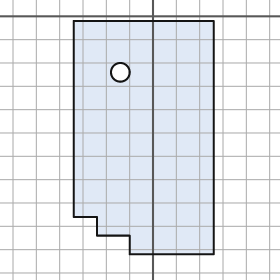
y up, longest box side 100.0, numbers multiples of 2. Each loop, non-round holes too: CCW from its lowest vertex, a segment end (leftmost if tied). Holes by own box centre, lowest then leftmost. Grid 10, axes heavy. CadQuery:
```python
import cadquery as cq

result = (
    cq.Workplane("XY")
    .moveTo(-10.0, -102.0)
    .lineTo(26.0, -102.0)
    .lineTo(26.0, -2.0)
    .lineTo(-34.0, -2.0)
    .lineTo(-34.0, -86.0)
    .lineTo(-24.0, -86.0)
    .lineTo(-24.0, -94.0)
    .lineTo(-10.0, -94.0)
    .close()
    .moveTo(-14.0, -24.0)
    .circle(4.0)
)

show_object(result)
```